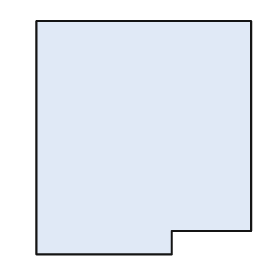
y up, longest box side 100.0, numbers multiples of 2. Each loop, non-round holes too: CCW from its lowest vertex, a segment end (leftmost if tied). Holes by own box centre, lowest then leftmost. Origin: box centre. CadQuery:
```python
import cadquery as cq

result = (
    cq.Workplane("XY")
    .moveTo(-46.0, -50.0)
    .lineTo(12.0, -50.0)
    .lineTo(12.0, -40.0)
    .lineTo(46.0, -40.0)
    .lineTo(46.0, 50.0)
    .lineTo(-46.0, 50.0)
    .close()
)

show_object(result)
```